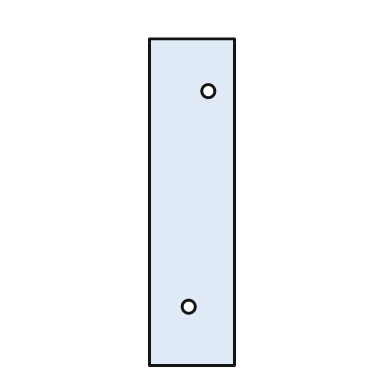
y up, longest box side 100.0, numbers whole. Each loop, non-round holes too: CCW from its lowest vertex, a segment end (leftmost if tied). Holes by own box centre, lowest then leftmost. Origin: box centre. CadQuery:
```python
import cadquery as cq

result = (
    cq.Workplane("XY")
    .moveTo(-13.0, -50.0)
    .lineTo(13.0, -50.0)
    .lineTo(13.0, 50.0)
    .lineTo(-13.0, 50.0)
    .close()
    .moveTo(-1.0, -32.0)
    .circle(2.0)
    .moveTo(5.0, 34.0)
    .circle(2.0)
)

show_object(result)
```